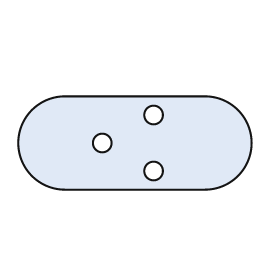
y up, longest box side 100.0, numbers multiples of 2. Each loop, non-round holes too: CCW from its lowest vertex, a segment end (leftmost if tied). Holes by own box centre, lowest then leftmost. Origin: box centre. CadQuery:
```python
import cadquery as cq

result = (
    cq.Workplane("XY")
    .moveTo(-30.0, -20.0)
    .lineTo(30.0, -20.0)
    .threePointArc((50.0, 0.0), (30.0, 20.0))
    .lineTo(-30.0, 20.0)
    .threePointArc((-50.0, 0.0), (-30.0, -20.0))
    .close()
    .moveTo(8.0, -12.0)
    .circle(4.0)
    .moveTo(-14.0, 0.0)
    .circle(4.0)
    .moveTo(8.0, 12.0)
    .circle(4.0)
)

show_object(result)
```